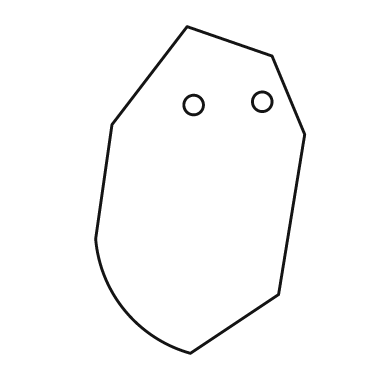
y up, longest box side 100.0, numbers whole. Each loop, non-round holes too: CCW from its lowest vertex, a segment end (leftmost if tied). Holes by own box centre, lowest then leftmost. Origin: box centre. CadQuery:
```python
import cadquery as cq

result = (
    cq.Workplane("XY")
    .moveTo(-3.0, -50.0)
    .lineTo(24.0, -32.0)
    .lineTo(32.0, 17.0)
    .lineTo(22.0, 41.0)
    .lineTo(-4.0, 50.0)
    .lineTo(-27.0, 20.0)
    .lineTo(-32.0, -15.0)
    .threePointArc((-23.0, -37.0), (-3.0, -50.0))
    .close()
    .moveTo(-2.0, 26.0)
    .circle(3.0)
    .moveTo(19.0, 27.0)
    .circle(3.0)
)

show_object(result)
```